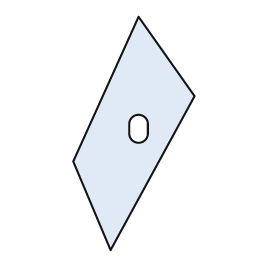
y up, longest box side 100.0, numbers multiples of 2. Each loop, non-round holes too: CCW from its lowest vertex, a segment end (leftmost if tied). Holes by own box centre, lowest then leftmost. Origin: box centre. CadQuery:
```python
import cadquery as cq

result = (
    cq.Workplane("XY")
    .moveTo(-10.0, -50.0)
    .lineTo(26.0, 16.0)
    .lineTo(2.0, 50.0)
    .lineTo(-26.0, -12.0)
    .close()
    .moveTo(-2.0, 0.0)
    .threePointArc((2.0, -4.0), (6.0, 0.0))
    .lineTo(6.0, 4.0)
    .threePointArc((2.0, 8.0), (-2.0, 4.0))
    .close()
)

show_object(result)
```